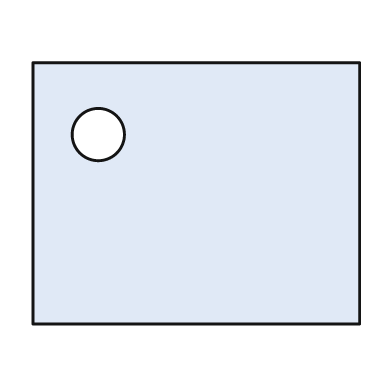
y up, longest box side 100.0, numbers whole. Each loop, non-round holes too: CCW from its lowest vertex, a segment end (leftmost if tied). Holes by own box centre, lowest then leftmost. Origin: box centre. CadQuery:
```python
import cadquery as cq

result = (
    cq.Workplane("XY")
    .moveTo(-50.0, -40.0)
    .lineTo(50.0, -40.0)
    .lineTo(50.0, 40.0)
    .lineTo(-50.0, 40.0)
    .close()
    .moveTo(-30.0, 18.0)
    .circle(8.0)
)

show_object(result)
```